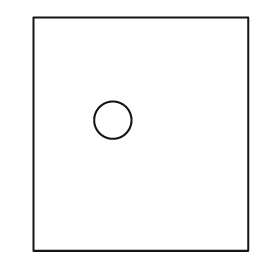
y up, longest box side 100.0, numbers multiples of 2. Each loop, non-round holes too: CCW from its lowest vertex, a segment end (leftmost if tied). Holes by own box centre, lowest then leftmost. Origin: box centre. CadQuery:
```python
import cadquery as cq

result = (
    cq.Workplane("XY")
    .moveTo(-46.0, -50.0)
    .lineTo(46.0, -50.0)
    .lineTo(46.0, 50.0)
    .lineTo(-46.0, 50.0)
    .close()
    .moveTo(-12.0, 6.0)
    .circle(8.0)
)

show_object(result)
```